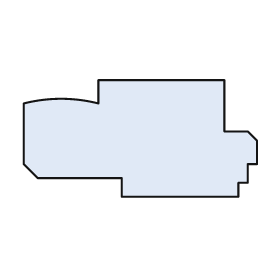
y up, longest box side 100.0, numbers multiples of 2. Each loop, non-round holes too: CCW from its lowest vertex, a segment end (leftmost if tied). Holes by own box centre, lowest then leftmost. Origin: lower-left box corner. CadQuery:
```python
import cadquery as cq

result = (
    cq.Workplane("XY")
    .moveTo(42.0, 0.0)
    .lineTo(92.0, 0.0)
    .lineTo(92.0, 6.0)
    .lineTo(96.0, 6.0)
    .lineTo(96.0, 14.0)
    .lineTo(100.0, 14.0)
    .lineTo(100.0, 24.0)
    .lineTo(96.0, 28.0)
    .lineTo(86.0, 28.0)
    .lineTo(86.0, 50.0)
    .lineTo(32.0, 50.0)
    .lineTo(32.0, 40.0)
    .threePointArc((16.0, 42.0), (0.0, 40.0))
    .lineTo(0.0, 14.0)
    .lineTo(6.0, 8.0)
    .lineTo(42.0, 8.0)
    .close()
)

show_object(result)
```